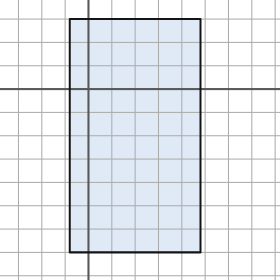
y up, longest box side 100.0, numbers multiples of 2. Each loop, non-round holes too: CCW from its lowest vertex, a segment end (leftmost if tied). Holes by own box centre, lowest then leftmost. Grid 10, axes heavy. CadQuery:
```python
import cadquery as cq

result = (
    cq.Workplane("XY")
    .moveTo(-8.0, -70.0)
    .lineTo(48.0, -70.0)
    .lineTo(48.0, 30.0)
    .lineTo(-8.0, 30.0)
    .close()
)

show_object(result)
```